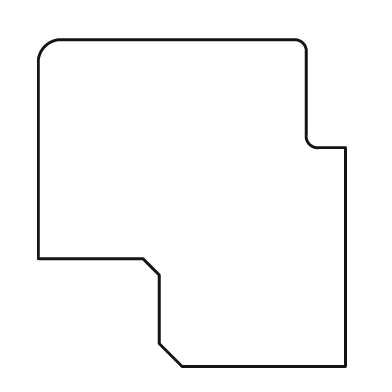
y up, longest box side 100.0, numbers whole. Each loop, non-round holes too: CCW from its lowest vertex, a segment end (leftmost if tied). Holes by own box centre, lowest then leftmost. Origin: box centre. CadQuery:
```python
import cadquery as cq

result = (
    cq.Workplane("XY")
    .moveTo(-3.0, -50.0)
    .lineTo(47.0, -50.0)
    .lineTo(47.0, 17.0)
    .lineTo(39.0, 17.0)
    .threePointArc((36.0, 18.0), (35.0, 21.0))
    .lineTo(35.0, 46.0)
    .threePointArc((34.0, 49.0), (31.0, 50.0))
    .lineTo(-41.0, 50.0)
    .threePointArc((-45.0, 48.0), (-47.0, 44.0))
    .lineTo(-47.0, -17.0)
    .lineTo(-15.0, -17.0)
    .lineTo(-10.0, -22.0)
    .lineTo(-10.0, -43.0)
    .close()
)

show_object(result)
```